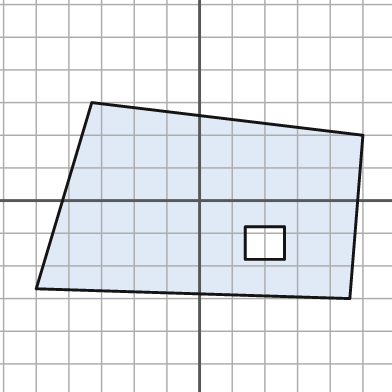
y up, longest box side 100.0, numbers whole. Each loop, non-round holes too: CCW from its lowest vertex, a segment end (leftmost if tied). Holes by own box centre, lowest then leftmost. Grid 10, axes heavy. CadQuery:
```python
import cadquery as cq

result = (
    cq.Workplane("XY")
    .moveTo(46.0, -30.0)
    .lineTo(50.0, 20.0)
    .lineTo(-33.0, 30.0)
    .lineTo(-50.0, -27.0)
    .close()
    .moveTo(14.0, -18.0)
    .lineTo(26.0, -18.0)
    .lineTo(26.0, -8.0)
    .lineTo(14.0, -8.0)
    .close()
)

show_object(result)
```